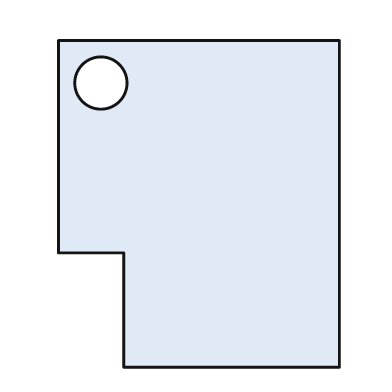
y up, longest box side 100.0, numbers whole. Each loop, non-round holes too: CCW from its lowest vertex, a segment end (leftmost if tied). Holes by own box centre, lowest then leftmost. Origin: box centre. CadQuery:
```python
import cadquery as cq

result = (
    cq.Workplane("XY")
    .moveTo(-23.0, -50.0)
    .lineTo(43.0, -50.0)
    .lineTo(43.0, 50.0)
    .lineTo(-43.0, 50.0)
    .lineTo(-43.0, -15.0)
    .lineTo(-23.0, -15.0)
    .close()
    .moveTo(-30.0, 37.0)
    .circle(8.0)
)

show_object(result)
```